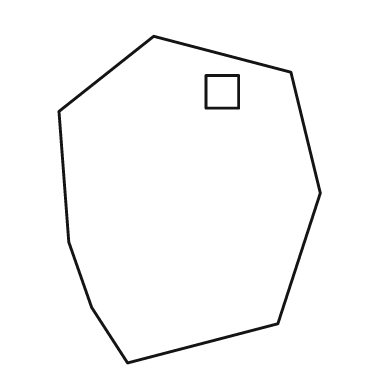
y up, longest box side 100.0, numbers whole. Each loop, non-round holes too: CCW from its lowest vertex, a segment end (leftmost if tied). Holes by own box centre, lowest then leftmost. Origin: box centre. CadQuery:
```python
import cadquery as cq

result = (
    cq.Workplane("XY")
    .moveTo(-19.0, -50.0)
    .lineTo(27.0, -38.0)
    .lineTo(40.0, 2.0)
    .lineTo(31.0, 39.0)
    .lineTo(-11.0, 50.0)
    .lineTo(-40.0, 27.0)
    .lineTo(-37.0, -13.0)
    .lineTo(-30.0, -33.0)
    .close()
    .moveTo(5.0, 28.0)
    .lineTo(15.0, 28.0)
    .lineTo(15.0, 38.0)
    .lineTo(5.0, 38.0)
    .close()
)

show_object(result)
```